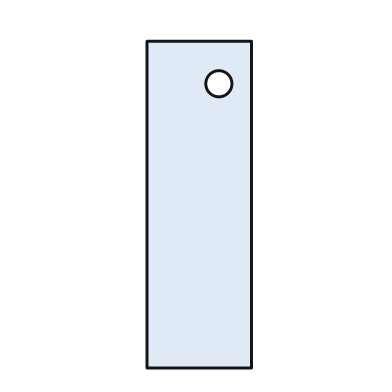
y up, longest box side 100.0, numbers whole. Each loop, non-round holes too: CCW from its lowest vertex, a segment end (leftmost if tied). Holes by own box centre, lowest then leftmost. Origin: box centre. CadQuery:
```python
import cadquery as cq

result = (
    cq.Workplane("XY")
    .moveTo(-16.0, -50.0)
    .lineTo(16.0, -50.0)
    .lineTo(16.0, 50.0)
    .lineTo(-16.0, 50.0)
    .close()
    .moveTo(6.0, 37.0)
    .circle(4.0)
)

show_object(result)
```